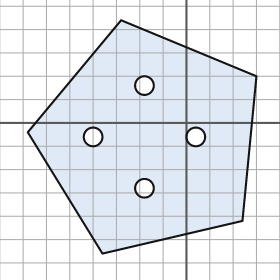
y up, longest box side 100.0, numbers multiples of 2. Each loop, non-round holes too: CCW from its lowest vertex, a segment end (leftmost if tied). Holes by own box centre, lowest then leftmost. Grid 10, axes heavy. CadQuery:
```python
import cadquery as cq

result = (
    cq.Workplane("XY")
    .moveTo(-36.0, -56.0)
    .lineTo(24.0, -42.0)
    .lineTo(30.0, 20.0)
    .lineTo(-28.0, 44.0)
    .lineTo(-68.0, -4.0)
    .close()
    .moveTo(-18.0, -28.0)
    .circle(4.0)
    .moveTo(-40.0, -6.0)
    .circle(4.0)
    .moveTo(4.0, -6.0)
    .circle(4.0)
    .moveTo(-18.0, 16.0)
    .circle(4.0)
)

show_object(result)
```